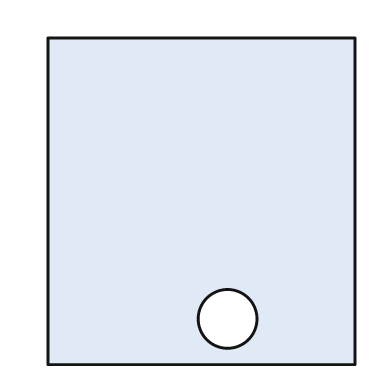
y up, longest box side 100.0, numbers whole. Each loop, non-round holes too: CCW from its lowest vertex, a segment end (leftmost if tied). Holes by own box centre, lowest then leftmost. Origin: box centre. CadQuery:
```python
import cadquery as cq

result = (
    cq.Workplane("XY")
    .moveTo(-47.0, -50.0)
    .lineTo(47.0, -50.0)
    .lineTo(47.0, 50.0)
    .lineTo(-47.0, 50.0)
    .close()
    .moveTo(8.0, -36.0)
    .circle(9.0)
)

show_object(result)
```